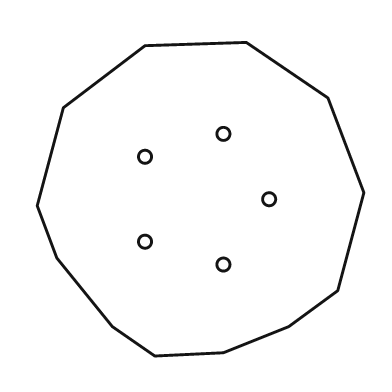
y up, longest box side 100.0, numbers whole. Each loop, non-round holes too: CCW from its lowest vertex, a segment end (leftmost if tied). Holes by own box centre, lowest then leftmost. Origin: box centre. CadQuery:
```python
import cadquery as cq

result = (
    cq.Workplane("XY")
    .moveTo(-14.0, -48.0)
    .lineTo(7.0, -47.0)
    .lineTo(27.0, -39.0)
    .lineTo(42.0, -28.0)
    .lineTo(50.0, 2.0)
    .lineTo(39.0, 31.0)
    .lineTo(14.0, 48.0)
    .lineTo(-17.0, 47.0)
    .lineTo(-42.0, 28.0)
    .lineTo(-50.0, -2.0)
    .lineTo(-44.0, -18.0)
    .lineTo(-27.0, -39.0)
    .close()
    .moveTo(7.0, -20.0)
    .circle(2.0)
    .moveTo(-17.0, -13.0)
    .circle(2.0)
    .moveTo(21.0, 0.0)
    .circle(2.0)
    .moveTo(-17.0, 13.0)
    .circle(2.0)
    .moveTo(7.0, 20.0)
    .circle(2.0)
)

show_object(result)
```